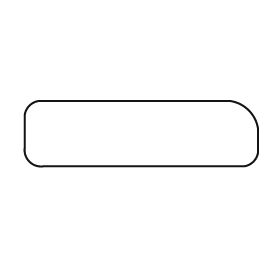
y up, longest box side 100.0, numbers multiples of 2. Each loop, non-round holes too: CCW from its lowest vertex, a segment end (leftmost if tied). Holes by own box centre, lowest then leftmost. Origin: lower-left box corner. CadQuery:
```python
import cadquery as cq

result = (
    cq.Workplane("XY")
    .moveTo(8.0, 0.0)
    .lineTo(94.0, 0.0)
    .threePointArc((98.0, 2.0), (100.0, 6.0))
    .lineTo(100.0, 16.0)
    .threePointArc((96.0, 24.0), (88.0, 28.0))
    .lineTo(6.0, 28.0)
    .threePointArc((2.0, 26.0), (0.0, 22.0))
    .lineTo(0.0, 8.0)
    .threePointArc((2.0, 2.0), (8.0, 0.0))
    .close()
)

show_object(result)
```